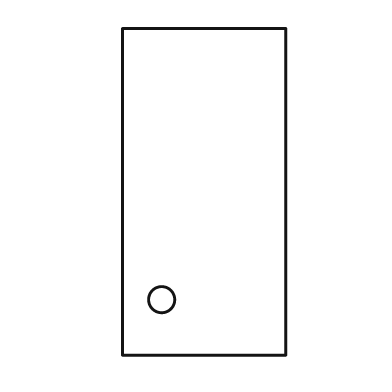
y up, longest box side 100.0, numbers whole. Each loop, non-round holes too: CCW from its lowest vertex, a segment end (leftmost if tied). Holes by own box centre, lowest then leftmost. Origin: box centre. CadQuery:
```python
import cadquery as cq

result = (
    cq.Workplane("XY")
    .moveTo(-25.0, -50.0)
    .lineTo(25.0, -50.0)
    .lineTo(25.0, 50.0)
    .lineTo(-25.0, 50.0)
    .close()
    .moveTo(-13.0, -33.0)
    .circle(4.0)
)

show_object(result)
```